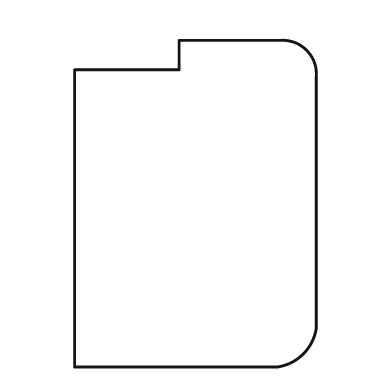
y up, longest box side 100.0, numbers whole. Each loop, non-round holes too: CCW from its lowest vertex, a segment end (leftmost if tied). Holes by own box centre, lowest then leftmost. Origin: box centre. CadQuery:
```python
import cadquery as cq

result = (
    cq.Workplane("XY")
    .moveTo(-37.0, -50.0)
    .lineTo(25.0, -50.0)
    .threePointArc((33.0, -46.0), (37.0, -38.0))
    .lineTo(37.0, 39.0)
    .threePointArc((34.0, 47.0), (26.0, 50.0))
    .lineTo(-5.0, 50.0)
    .lineTo(-5.0, 41.0)
    .lineTo(-37.0, 41.0)
    .close()
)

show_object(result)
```